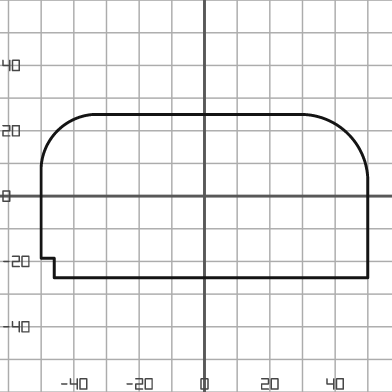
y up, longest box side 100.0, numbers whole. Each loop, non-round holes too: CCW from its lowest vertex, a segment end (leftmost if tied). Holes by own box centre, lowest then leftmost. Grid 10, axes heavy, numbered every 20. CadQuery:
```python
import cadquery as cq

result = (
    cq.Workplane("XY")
    .moveTo(-46.0, -25.0)
    .lineTo(50.0, -25.0)
    .lineTo(50.0, 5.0)
    .threePointArc((44.0, 19.0), (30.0, 25.0))
    .lineTo(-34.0, 25.0)
    .threePointArc((-45.0, 20.0), (-50.0, 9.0))
    .lineTo(-50.0, -19.0)
    .lineTo(-46.0, -19.0)
    .close()
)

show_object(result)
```